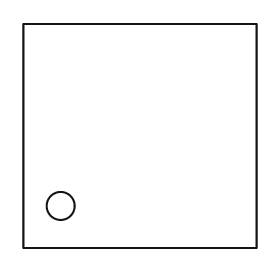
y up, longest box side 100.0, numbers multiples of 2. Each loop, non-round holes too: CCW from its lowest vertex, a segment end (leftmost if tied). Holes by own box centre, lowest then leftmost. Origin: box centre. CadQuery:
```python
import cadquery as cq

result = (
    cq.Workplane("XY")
    .moveTo(-50.0, -48.0)
    .lineTo(50.0, -48.0)
    .lineTo(50.0, 48.0)
    .lineTo(-50.0, 48.0)
    .close()
    .moveTo(-34.0, -30.0)
    .circle(6.0)
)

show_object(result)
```